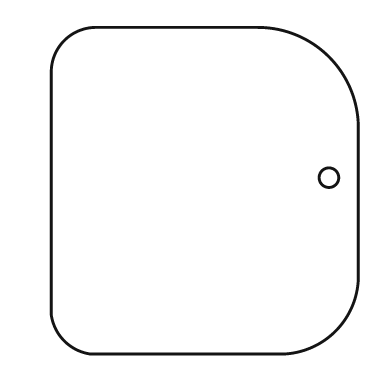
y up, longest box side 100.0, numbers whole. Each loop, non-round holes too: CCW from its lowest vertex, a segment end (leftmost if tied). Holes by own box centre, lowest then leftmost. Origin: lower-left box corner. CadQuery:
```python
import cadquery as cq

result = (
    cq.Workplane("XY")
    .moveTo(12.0, 0.0)
    .lineTo(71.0, 0.0)
    .threePointArc((87.0, 7.0), (94.0, 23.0))
    .lineTo(94.0, 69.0)
    .threePointArc((85.0, 91.0), (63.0, 100.0))
    .lineTo(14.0, 100.0)
    .threePointArc((4.0, 96.0), (0.0, 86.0))
    .lineTo(0.0, 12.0)
    .threePointArc((4.0, 4.0), (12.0, 0.0))
    .close()
    .moveTo(85.0, 54.0)
    .circle(3.0)
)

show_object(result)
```